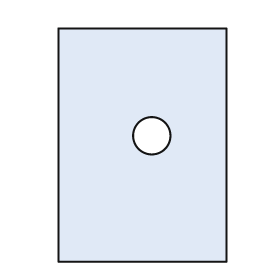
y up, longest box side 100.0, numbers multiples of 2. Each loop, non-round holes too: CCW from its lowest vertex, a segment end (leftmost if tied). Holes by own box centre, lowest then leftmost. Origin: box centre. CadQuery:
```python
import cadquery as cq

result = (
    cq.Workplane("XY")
    .moveTo(-36.0, -50.0)
    .lineTo(36.0, -50.0)
    .lineTo(36.0, 50.0)
    .lineTo(-36.0, 50.0)
    .close()
    .moveTo(4.0, 4.0)
    .circle(8.0)
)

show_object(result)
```